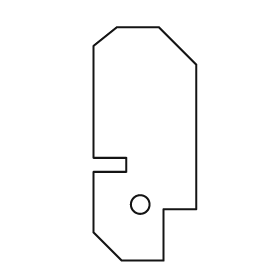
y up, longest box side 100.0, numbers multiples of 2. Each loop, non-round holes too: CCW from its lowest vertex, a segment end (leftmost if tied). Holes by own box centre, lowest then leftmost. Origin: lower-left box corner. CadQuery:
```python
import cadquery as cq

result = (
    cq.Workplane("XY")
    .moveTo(12.0, 0.0)
    .lineTo(30.0, 0.0)
    .lineTo(30.0, 22.0)
    .lineTo(44.0, 22.0)
    .lineTo(44.0, 84.0)
    .lineTo(28.0, 100.0)
    .lineTo(10.0, 100.0)
    .lineTo(0.0, 92.0)
    .lineTo(0.0, 44.0)
    .lineTo(14.0, 44.0)
    .lineTo(14.0, 38.0)
    .lineTo(0.0, 38.0)
    .lineTo(0.0, 12.0)
    .close()
    .moveTo(20.0, 24.0)
    .circle(4.0)
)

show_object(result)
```